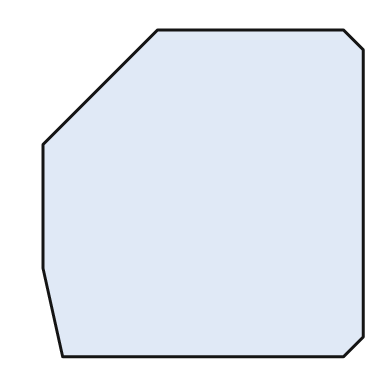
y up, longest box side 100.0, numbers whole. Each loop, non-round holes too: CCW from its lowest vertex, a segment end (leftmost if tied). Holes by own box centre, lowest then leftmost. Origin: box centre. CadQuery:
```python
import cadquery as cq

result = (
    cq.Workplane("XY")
    .moveTo(-43.0, -50.0)
    .lineTo(43.0, -50.0)
    .lineTo(49.0, -44.0)
    .lineTo(49.0, 44.0)
    .lineTo(43.0, 50.0)
    .lineTo(-14.0, 50.0)
    .lineTo(-49.0, 15.0)
    .lineTo(-49.0, -23.0)
    .close()
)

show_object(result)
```